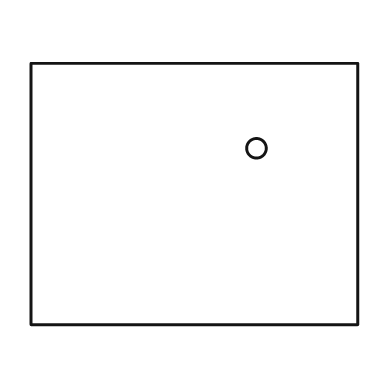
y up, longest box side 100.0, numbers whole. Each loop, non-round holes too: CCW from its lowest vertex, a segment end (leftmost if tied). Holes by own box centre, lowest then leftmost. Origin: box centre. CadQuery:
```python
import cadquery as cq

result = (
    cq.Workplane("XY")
    .moveTo(-50.0, -40.0)
    .lineTo(50.0, -40.0)
    .lineTo(50.0, 40.0)
    .lineTo(-50.0, 40.0)
    .close()
    .moveTo(19.0, 14.0)
    .circle(3.0)
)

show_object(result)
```